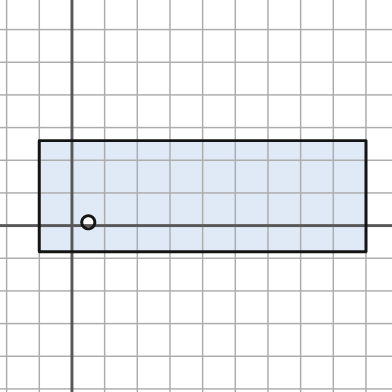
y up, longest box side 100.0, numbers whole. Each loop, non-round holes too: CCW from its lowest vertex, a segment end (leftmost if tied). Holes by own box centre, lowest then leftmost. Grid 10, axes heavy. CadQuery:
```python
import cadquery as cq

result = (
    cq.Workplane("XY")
    .moveTo(-10.0, -8.0)
    .lineTo(90.0, -8.0)
    .lineTo(90.0, 26.0)
    .lineTo(-10.0, 26.0)
    .close()
    .moveTo(5.0, 1.0)
    .circle(2.0)
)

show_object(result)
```